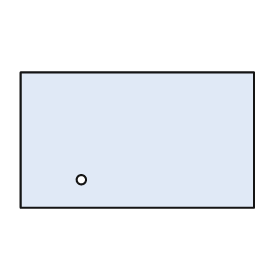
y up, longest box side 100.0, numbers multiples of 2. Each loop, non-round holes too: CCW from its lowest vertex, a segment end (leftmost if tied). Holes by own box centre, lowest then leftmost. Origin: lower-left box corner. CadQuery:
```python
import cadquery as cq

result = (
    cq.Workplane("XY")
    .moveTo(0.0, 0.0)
    .lineTo(100.0, 0.0)
    .lineTo(100.0, 58.0)
    .lineTo(0.0, 58.0)
    .close()
    .moveTo(26.0, 12.0)
    .circle(2.0)
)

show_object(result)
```